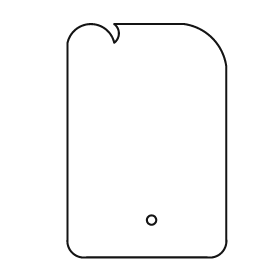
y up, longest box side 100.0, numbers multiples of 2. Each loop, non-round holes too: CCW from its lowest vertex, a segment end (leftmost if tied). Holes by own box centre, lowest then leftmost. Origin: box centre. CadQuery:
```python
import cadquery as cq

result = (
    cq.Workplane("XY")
    .moveTo(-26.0, -50.0)
    .lineTo(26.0, -50.0)
    .threePointArc((32.0, -48.0), (34.0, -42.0))
    .lineTo(34.0, 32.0)
    .threePointArc((28.0, 44.0), (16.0, 50.0))
    .lineTo(-14.0, 50.0)
    .threePointArc((-12.0, 46.0), (-14.0, 42.0))
    .threePointArc((-24.0, 50.0), (-34.0, 42.0))
    .lineTo(-34.0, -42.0)
    .threePointArc((-32.0, -48.0), (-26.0, -50.0))
    .close()
    .moveTo(2.0, -34.0)
    .circle(2.0)
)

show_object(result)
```